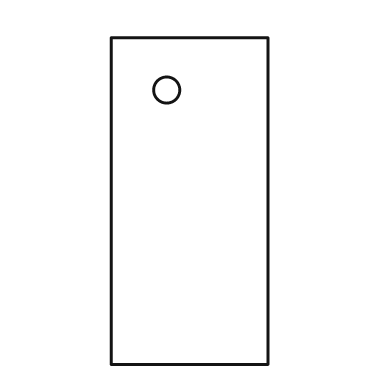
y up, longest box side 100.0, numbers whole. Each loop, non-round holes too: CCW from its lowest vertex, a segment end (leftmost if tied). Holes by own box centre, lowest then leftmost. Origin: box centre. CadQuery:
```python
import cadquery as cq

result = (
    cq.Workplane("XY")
    .moveTo(-24.0, -50.0)
    .lineTo(24.0, -50.0)
    .lineTo(24.0, 50.0)
    .lineTo(-24.0, 50.0)
    .close()
    .moveTo(-7.0, 34.0)
    .circle(4.0)
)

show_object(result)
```